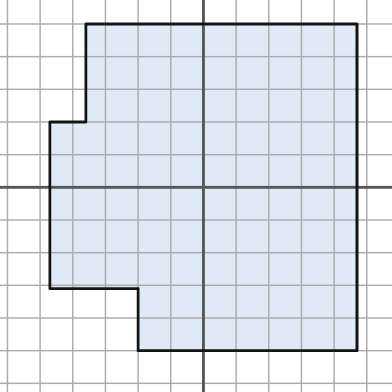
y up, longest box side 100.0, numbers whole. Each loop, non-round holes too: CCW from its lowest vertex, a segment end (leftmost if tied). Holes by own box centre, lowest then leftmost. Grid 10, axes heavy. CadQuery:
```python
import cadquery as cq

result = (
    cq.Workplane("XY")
    .moveTo(-20.0, -50.0)
    .lineTo(47.0, -50.0)
    .lineTo(47.0, 50.0)
    .lineTo(-36.0, 50.0)
    .lineTo(-36.0, 20.0)
    .lineTo(-47.0, 20.0)
    .lineTo(-47.0, -31.0)
    .lineTo(-20.0, -31.0)
    .close()
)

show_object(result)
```